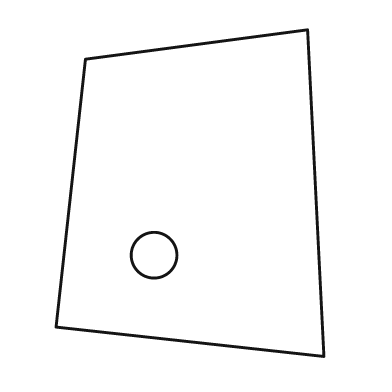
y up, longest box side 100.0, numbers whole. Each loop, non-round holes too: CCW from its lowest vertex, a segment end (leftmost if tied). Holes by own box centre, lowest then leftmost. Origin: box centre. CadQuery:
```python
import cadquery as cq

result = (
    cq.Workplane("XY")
    .moveTo(41.0, -50.0)
    .lineTo(36.0, 50.0)
    .lineTo(-32.0, 41.0)
    .lineTo(-41.0, -41.0)
    .close()
    .moveTo(-11.0, -19.0)
    .circle(7.0)
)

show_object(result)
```